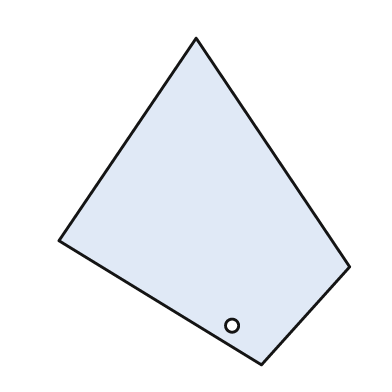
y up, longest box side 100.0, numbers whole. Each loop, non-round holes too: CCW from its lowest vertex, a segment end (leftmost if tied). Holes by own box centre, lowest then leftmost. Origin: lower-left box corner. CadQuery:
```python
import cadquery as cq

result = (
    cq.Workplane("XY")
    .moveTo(62.0, 0.0)
    .lineTo(89.0, 30.0)
    .lineTo(42.0, 100.0)
    .lineTo(0.0, 38.0)
    .close()
    .moveTo(53.0, 12.0)
    .circle(2.0)
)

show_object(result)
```